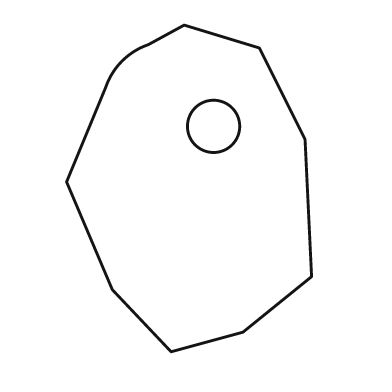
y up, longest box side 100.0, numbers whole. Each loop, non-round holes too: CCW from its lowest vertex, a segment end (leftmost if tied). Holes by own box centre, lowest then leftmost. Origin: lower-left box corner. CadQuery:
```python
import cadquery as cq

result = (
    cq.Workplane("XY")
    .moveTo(32.0, 0.0)
    .lineTo(54.0, 6.0)
    .lineTo(75.0, 23.0)
    .lineTo(73.0, 65.0)
    .lineTo(59.0, 93.0)
    .lineTo(36.0, 100.0)
    .lineTo(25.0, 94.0)
    .threePointArc((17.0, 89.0), (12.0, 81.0))
    .lineTo(0.0, 52.0)
    .lineTo(14.0, 19.0)
    .close()
    .moveTo(45.0, 69.0)
    .circle(8.0)
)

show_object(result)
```